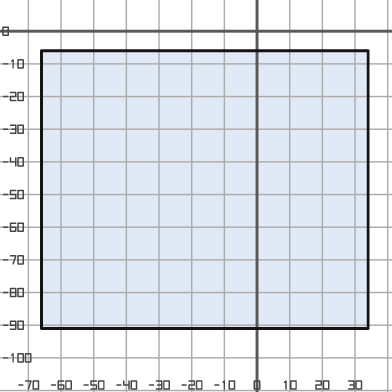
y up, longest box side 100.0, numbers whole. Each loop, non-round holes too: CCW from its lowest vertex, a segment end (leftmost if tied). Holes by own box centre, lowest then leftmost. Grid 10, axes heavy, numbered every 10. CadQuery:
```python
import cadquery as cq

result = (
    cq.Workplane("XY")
    .moveTo(-66.0, -91.0)
    .lineTo(34.0, -91.0)
    .lineTo(34.0, -6.0)
    .lineTo(-66.0, -6.0)
    .close()
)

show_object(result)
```